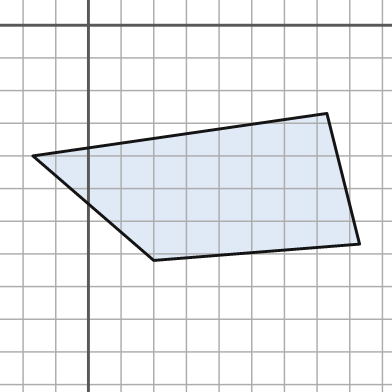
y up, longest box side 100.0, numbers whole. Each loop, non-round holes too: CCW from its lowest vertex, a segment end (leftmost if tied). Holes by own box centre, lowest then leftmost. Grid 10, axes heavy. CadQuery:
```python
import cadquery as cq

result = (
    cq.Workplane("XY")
    .moveTo(20.0, -72.0)
    .lineTo(83.0, -67.0)
    .lineTo(73.0, -27.0)
    .lineTo(-17.0, -40.0)
    .close()
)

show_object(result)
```